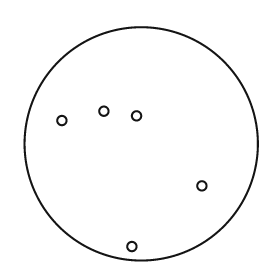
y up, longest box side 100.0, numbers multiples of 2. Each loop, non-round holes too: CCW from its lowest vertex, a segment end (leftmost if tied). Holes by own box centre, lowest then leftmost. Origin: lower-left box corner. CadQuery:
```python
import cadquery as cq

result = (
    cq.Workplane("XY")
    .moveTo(50.0, 50.0)
    .circle(50.0)
    .moveTo(46.0, 6.0)
    .circle(2.0)
    .moveTo(76.0, 32.0)
    .circle(2.0)
    .moveTo(16.0, 60.0)
    .circle(2.0)
    .moveTo(48.0, 62.0)
    .circle(2.0)
    .moveTo(34.0, 64.0)
    .circle(2.0)
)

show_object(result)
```